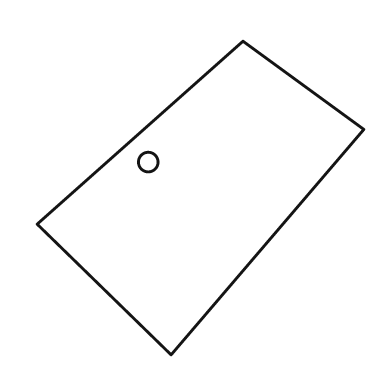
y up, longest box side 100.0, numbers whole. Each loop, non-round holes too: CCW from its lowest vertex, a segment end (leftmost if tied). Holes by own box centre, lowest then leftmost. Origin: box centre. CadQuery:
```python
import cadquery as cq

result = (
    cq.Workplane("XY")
    .moveTo(-9.0, -48.0)
    .lineTo(50.0, 21.0)
    .lineTo(13.0, 48.0)
    .lineTo(-50.0, -8.0)
    .close()
    .moveTo(-16.0, 11.0)
    .circle(3.0)
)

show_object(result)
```